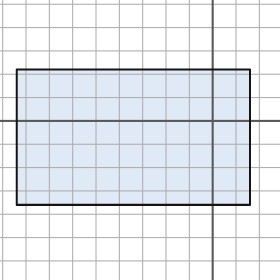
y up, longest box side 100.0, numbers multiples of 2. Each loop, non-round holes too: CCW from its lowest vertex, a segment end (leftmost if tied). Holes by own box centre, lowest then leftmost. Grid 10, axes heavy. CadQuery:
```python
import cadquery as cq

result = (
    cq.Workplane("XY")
    .moveTo(-84.0, -36.0)
    .lineTo(16.0, -36.0)
    .lineTo(16.0, 22.0)
    .lineTo(-84.0, 22.0)
    .close()
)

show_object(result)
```